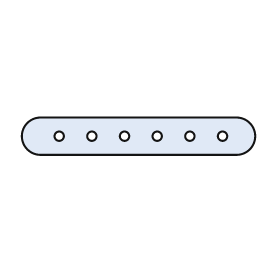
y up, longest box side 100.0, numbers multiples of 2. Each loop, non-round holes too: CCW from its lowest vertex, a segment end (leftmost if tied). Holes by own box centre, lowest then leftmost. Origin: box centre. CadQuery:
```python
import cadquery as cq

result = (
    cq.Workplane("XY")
    .moveTo(-42.0, -8.0)
    .lineTo(42.0, -8.0)
    .threePointArc((50.0, 0.0), (42.0, 8.0))
    .lineTo(-42.0, 8.0)
    .threePointArc((-50.0, 0.0), (-42.0, -8.0))
    .close()
    .moveTo(-34.0, 0.0)
    .circle(2.0)
    .moveTo(-20.0, 0.0)
    .circle(2.0)
    .moveTo(-6.0, 0.0)
    .circle(2.0)
    .moveTo(8.0, 0.0)
    .circle(2.0)
    .moveTo(22.0, 0.0)
    .circle(2.0)
    .moveTo(36.0, 0.0)
    .circle(2.0)
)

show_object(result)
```